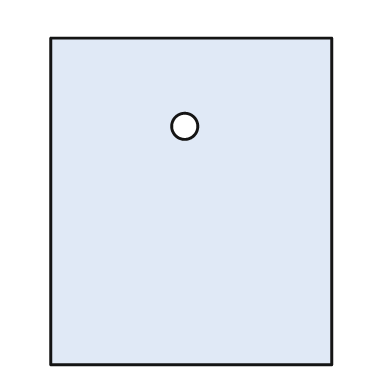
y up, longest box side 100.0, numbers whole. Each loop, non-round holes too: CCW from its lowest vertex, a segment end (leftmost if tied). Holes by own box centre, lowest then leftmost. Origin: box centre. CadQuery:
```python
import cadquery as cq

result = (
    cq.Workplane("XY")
    .moveTo(-43.0, -50.0)
    .lineTo(43.0, -50.0)
    .lineTo(43.0, 50.0)
    .lineTo(-43.0, 50.0)
    .close()
    .moveTo(-2.0, 23.0)
    .circle(4.0)
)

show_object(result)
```